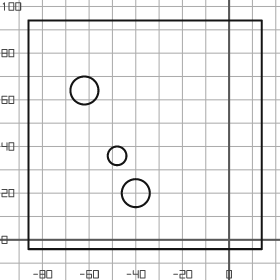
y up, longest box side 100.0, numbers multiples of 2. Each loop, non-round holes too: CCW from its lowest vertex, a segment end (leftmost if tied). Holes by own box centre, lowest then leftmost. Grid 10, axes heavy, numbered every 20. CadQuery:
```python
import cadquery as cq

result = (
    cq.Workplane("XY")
    .moveTo(-86.0, -4.0)
    .lineTo(14.0, -4.0)
    .lineTo(14.0, 94.0)
    .lineTo(-86.0, 94.0)
    .close()
    .moveTo(-40.0, 20.0)
    .circle(6.0)
    .moveTo(-48.0, 36.0)
    .circle(4.0)
    .moveTo(-62.0, 64.0)
    .circle(6.0)
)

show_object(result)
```